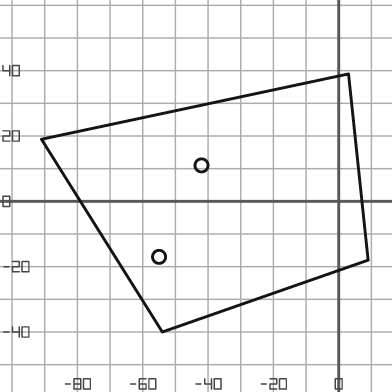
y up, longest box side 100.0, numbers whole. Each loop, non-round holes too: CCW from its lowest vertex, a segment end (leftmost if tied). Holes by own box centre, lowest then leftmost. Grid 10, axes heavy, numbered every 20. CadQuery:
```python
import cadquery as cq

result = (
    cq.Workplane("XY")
    .moveTo(-54.0, -40.0)
    .lineTo(9.0, -18.0)
    .lineTo(3.0, 39.0)
    .lineTo(-91.0, 19.0)
    .close()
    .moveTo(-55.0, -17.0)
    .circle(2.0)
    .moveTo(-42.0, 11.0)
    .circle(2.0)
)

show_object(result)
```